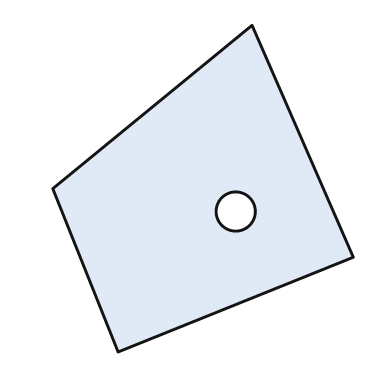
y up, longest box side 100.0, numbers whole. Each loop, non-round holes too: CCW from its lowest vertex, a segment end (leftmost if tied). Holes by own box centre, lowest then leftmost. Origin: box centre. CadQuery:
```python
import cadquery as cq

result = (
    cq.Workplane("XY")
    .moveTo(-26.0, -50.0)
    .lineTo(46.0, -21.0)
    .lineTo(15.0, 50.0)
    .lineTo(-46.0, 0.0)
    .close()
    .moveTo(10.0, -7.0)
    .circle(6.0)
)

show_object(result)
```